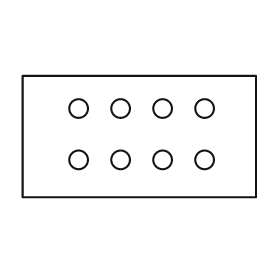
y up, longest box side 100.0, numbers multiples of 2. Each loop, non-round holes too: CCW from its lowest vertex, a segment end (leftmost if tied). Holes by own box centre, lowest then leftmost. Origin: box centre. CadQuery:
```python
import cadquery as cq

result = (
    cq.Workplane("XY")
    .moveTo(-50.0, -26.0)
    .lineTo(50.0, -26.0)
    .lineTo(50.0, 26.0)
    .lineTo(-50.0, 26.0)
    .close()
    .moveTo(-26.0, -10.0)
    .circle(4.0)
    .moveTo(-8.0, -10.0)
    .circle(4.0)
    .moveTo(10.0, -10.0)
    .circle(4.0)
    .moveTo(28.0, -10.0)
    .circle(4.0)
    .moveTo(-26.0, 12.0)
    .circle(4.0)
    .moveTo(-8.0, 12.0)
    .circle(4.0)
    .moveTo(10.0, 12.0)
    .circle(4.0)
    .moveTo(28.0, 12.0)
    .circle(4.0)
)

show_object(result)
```